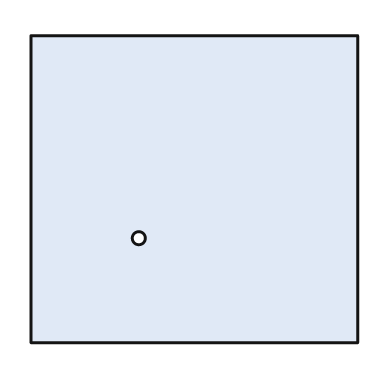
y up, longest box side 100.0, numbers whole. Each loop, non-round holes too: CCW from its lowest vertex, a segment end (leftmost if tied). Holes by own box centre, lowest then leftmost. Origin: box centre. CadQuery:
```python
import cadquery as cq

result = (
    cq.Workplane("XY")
    .moveTo(-50.0, -47.0)
    .lineTo(50.0, -47.0)
    .lineTo(50.0, 47.0)
    .lineTo(-50.0, 47.0)
    .close()
    .moveTo(-17.0, -15.0)
    .circle(2.0)
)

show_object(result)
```